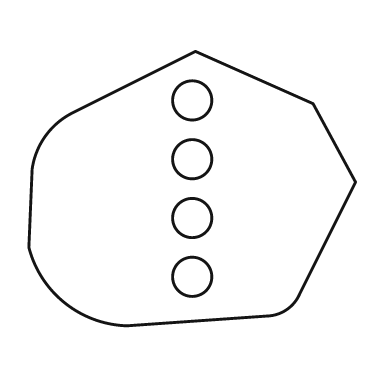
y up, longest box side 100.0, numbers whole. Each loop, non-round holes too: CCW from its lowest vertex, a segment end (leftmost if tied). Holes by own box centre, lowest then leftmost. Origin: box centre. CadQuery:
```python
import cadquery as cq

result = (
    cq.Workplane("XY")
    .moveTo(-20.0, -42.0)
    .lineTo(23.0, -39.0)
    .threePointArc((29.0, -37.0), (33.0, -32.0))
    .lineTo(50.0, 2.0)
    .lineTo(37.0, 26.0)
    .lineTo(1.0, 42.0)
    .lineTo(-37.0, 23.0)
    .threePointArc((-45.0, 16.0), (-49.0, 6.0))
    .lineTo(-50.0, -18.0)
    .threePointArc((-39.0, -35.0), (-20.0, -42.0))
    .close()
    .moveTo(0.0, -27.0)
    .circle(6.0)
    .moveTo(0.0, -9.0)
    .circle(6.0)
    .moveTo(0.0, 9.0)
    .circle(6.0)
    .moveTo(0.0, 27.0)
    .circle(6.0)
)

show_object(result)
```